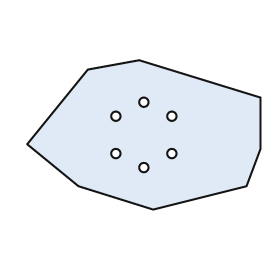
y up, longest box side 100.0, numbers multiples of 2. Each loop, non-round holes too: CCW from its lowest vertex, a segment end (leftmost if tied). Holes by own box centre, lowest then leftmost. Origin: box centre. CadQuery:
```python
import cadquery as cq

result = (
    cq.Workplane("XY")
    .moveTo(4.0, -32.0)
    .lineTo(44.0, -22.0)
    .lineTo(50.0, -6.0)
    .lineTo(50.0, 16.0)
    .lineTo(-2.0, 32.0)
    .lineTo(-24.0, 28.0)
    .lineTo(-50.0, -4.0)
    .lineTo(-28.0, -22.0)
    .close()
    .moveTo(0.0, -14.0)
    .circle(2.0)
    .moveTo(-12.0, -8.0)
    .circle(2.0)
    .moveTo(12.0, -8.0)
    .circle(2.0)
    .moveTo(-12.0, 8.0)
    .circle(2.0)
    .moveTo(12.0, 8.0)
    .circle(2.0)
    .moveTo(0.0, 14.0)
    .circle(2.0)
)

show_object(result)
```